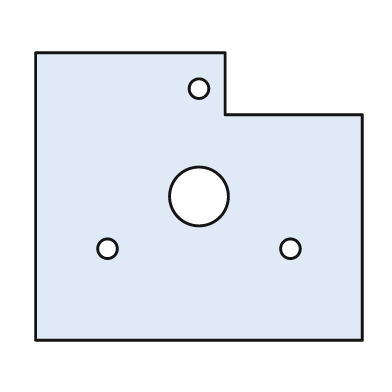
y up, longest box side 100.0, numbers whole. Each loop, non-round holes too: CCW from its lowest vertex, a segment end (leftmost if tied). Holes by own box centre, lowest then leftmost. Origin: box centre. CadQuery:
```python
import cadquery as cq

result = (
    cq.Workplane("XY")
    .moveTo(-50.0, -44.0)
    .lineTo(50.0, -44.0)
    .lineTo(50.0, 25.0)
    .lineTo(8.0, 25.0)
    .lineTo(8.0, 44.0)
    .lineTo(-50.0, 44.0)
    .close()
    .moveTo(-28.0, -16.0)
    .circle(3.0)
    .moveTo(28.0, -16.0)
    .circle(3.0)
    .moveTo(0.0, 0.0)
    .circle(9.0)
    .moveTo(0.0, 33.0)
    .circle(3.0)
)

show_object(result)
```